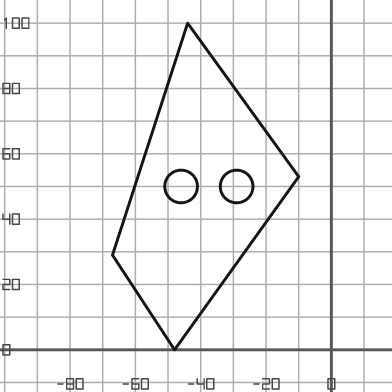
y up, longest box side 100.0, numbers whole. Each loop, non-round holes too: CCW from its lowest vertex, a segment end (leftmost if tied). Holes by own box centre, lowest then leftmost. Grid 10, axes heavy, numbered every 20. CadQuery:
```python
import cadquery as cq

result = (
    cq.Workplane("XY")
    .moveTo(-48.0, 0.0)
    .lineTo(-10.0, 53.0)
    .lineTo(-44.0, 100.0)
    .lineTo(-67.0, 29.0)
    .close()
    .moveTo(-46.0, 50.0)
    .circle(5.0)
    .moveTo(-29.0, 50.0)
    .circle(5.0)
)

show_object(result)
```